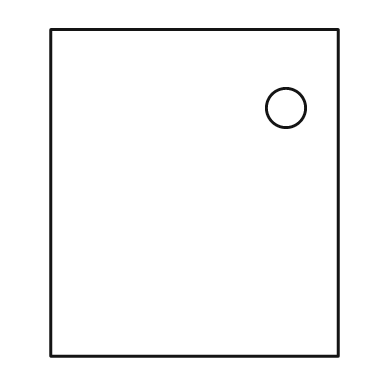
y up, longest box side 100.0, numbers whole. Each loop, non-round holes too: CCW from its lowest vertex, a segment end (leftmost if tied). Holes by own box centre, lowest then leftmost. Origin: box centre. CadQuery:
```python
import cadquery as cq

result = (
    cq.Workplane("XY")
    .moveTo(-44.0, -50.0)
    .lineTo(44.0, -50.0)
    .lineTo(44.0, 50.0)
    .lineTo(-44.0, 50.0)
    .close()
    .moveTo(28.0, 26.0)
    .circle(6.0)
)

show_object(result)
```